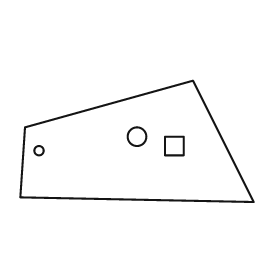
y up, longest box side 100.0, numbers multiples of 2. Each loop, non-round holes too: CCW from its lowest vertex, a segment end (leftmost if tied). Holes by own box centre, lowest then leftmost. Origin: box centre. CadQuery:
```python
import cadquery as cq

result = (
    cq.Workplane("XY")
    .moveTo(50.0, -26.0)
    .lineTo(24.0, 26.0)
    .lineTo(-48.0, 6.0)
    .lineTo(-50.0, -24.0)
    .close()
    .moveTo(-42.0, -4.0)
    .circle(2.0)
    .moveTo(12.0, -6.0)
    .lineTo(20.0, -6.0)
    .lineTo(20.0, 2.0)
    .lineTo(12.0, 2.0)
    .close()
    .moveTo(0.0, 2.0)
    .circle(4.0)
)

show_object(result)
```